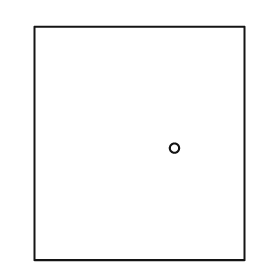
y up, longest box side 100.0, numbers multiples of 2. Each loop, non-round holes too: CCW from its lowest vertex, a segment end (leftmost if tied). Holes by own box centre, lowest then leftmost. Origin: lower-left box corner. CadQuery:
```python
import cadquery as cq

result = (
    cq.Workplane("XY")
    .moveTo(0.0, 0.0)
    .lineTo(90.0, 0.0)
    .lineTo(90.0, 100.0)
    .lineTo(0.0, 100.0)
    .close()
    .moveTo(60.0, 48.0)
    .circle(2.0)
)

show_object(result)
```